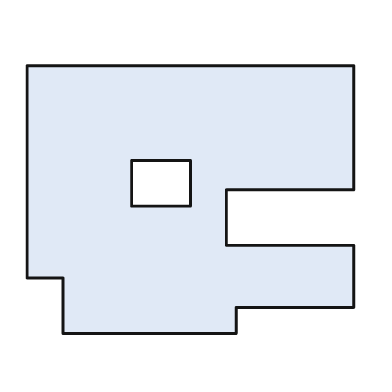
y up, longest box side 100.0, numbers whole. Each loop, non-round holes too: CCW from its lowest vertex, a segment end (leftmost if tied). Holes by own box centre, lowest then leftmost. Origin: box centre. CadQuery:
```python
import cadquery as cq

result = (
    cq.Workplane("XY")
    .moveTo(-39.0, -41.0)
    .lineTo(14.0, -41.0)
    .lineTo(14.0, -33.0)
    .lineTo(50.0, -33.0)
    .lineTo(50.0, -14.0)
    .lineTo(11.0, -14.0)
    .lineTo(11.0, 3.0)
    .lineTo(50.0, 3.0)
    .lineTo(50.0, 41.0)
    .lineTo(-50.0, 41.0)
    .lineTo(-50.0, -24.0)
    .lineTo(-39.0, -24.0)
    .close()
    .moveTo(-18.0, -2.0)
    .lineTo(0.0, -2.0)
    .lineTo(0.0, 12.0)
    .lineTo(-18.0, 12.0)
    .close()
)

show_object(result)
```